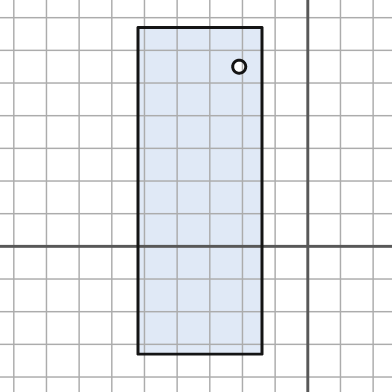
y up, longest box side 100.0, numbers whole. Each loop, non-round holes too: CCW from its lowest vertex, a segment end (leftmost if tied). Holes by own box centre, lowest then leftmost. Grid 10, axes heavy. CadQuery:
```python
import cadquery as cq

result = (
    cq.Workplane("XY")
    .moveTo(-52.0, -33.0)
    .lineTo(-14.0, -33.0)
    .lineTo(-14.0, 67.0)
    .lineTo(-52.0, 67.0)
    .close()
    .moveTo(-21.0, 55.0)
    .circle(2.0)
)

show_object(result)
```